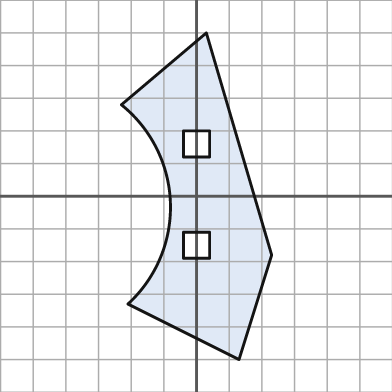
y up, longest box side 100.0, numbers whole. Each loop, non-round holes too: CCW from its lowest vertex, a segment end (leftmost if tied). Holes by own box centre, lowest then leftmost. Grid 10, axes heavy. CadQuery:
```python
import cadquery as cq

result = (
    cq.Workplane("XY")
    .moveTo(13.0, -50.0)
    .lineTo(23.0, -18.0)
    .lineTo(3.0, 50.0)
    .lineTo(-23.0, 28.0)
    .threePointArc((-8.0, -2.0), (-21.0, -33.0))
    .close()
    .moveTo(-4.0, -19.0)
    .lineTo(4.0, -19.0)
    .lineTo(4.0, -11.0)
    .lineTo(-4.0, -11.0)
    .close()
    .moveTo(-4.0, 12.0)
    .lineTo(4.0, 12.0)
    .lineTo(4.0, 20.0)
    .lineTo(-4.0, 20.0)
    .close()
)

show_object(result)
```